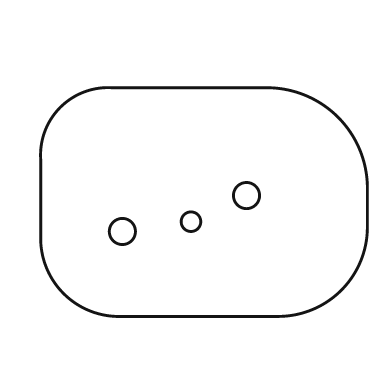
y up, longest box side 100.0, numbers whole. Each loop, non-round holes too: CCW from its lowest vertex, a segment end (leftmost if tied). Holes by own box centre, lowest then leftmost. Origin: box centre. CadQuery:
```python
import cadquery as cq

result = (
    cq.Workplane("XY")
    .moveTo(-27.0, -35.0)
    .lineTo(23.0, -35.0)
    .threePointArc((42.0, -27.0), (50.0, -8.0))
    .lineTo(50.0, 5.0)
    .threePointArc((41.0, 26.0), (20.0, 35.0))
    .lineTo(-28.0, 35.0)
    .threePointArc((-44.0, 29.0), (-50.0, 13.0))
    .lineTo(-50.0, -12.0)
    .threePointArc((-43.0, -28.0), (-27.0, -35.0))
    .close()
    .moveTo(-25.0, -9.0)
    .circle(4.0)
    .moveTo(-4.0, -6.0)
    .circle(3.0)
    .moveTo(13.0, 2.0)
    .circle(4.0)
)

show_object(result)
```